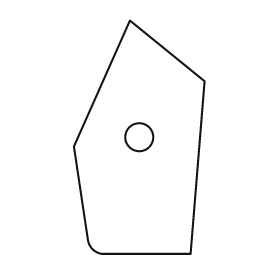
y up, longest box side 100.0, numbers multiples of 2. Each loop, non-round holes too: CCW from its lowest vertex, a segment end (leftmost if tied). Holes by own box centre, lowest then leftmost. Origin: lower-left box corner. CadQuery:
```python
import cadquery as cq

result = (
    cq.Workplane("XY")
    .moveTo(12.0, 0.0)
    .lineTo(50.0, 0.0)
    .lineTo(56.0, 74.0)
    .lineTo(24.0, 100.0)
    .lineTo(0.0, 46.0)
    .lineTo(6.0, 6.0)
    .threePointArc((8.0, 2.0), (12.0, 0.0))
    .close()
    .moveTo(28.0, 50.0)
    .circle(6.0)
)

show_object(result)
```